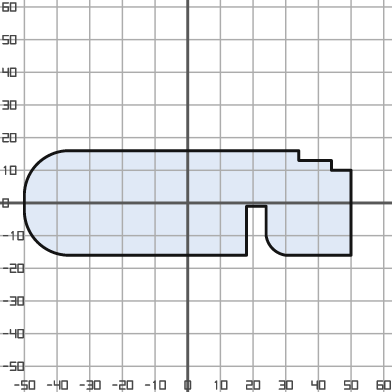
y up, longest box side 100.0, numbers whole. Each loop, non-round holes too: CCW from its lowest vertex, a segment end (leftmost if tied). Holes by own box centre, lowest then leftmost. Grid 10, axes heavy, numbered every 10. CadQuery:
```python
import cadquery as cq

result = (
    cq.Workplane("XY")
    .moveTo(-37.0, -16.0)
    .lineTo(18.0, -16.0)
    .lineTo(18.0, -1.0)
    .lineTo(24.0, -1.0)
    .lineTo(24.0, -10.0)
    .threePointArc((26.0, -14.0), (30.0, -16.0))
    .lineTo(50.0, -16.0)
    .lineTo(50.0, 10.0)
    .lineTo(44.0, 10.0)
    .lineTo(44.0, 13.0)
    .lineTo(34.0, 13.0)
    .lineTo(34.0, 16.0)
    .lineTo(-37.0, 16.0)
    .threePointArc((-46.0, 12.0), (-50.0, 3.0))
    .lineTo(-50.0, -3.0)
    .threePointArc((-46.0, -12.0), (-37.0, -16.0))
    .close()
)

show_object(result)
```